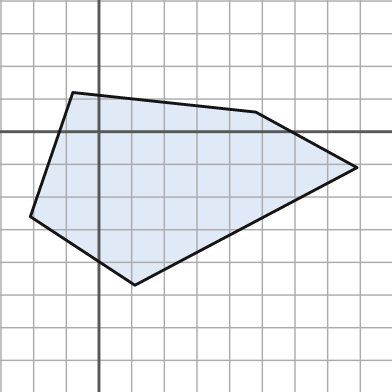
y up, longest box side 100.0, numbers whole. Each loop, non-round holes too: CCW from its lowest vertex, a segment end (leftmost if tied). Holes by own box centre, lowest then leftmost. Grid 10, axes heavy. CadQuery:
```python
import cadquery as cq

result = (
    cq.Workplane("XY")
    .moveTo(11.0, -47.0)
    .lineTo(79.0, -11.0)
    .lineTo(48.0, 6.0)
    .lineTo(-8.0, 12.0)
    .lineTo(-21.0, -26.0)
    .close()
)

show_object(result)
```